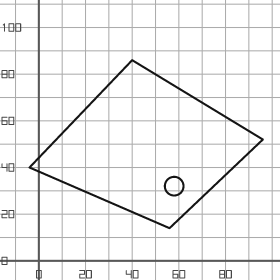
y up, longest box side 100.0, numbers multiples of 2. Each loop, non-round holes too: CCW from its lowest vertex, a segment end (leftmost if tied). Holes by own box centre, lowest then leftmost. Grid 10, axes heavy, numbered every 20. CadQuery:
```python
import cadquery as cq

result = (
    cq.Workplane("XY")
    .moveTo(56.0, 14.0)
    .lineTo(96.0, 52.0)
    .lineTo(40.0, 86.0)
    .lineTo(-4.0, 40.0)
    .close()
    .moveTo(58.0, 32.0)
    .circle(4.0)
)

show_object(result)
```